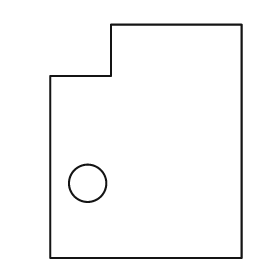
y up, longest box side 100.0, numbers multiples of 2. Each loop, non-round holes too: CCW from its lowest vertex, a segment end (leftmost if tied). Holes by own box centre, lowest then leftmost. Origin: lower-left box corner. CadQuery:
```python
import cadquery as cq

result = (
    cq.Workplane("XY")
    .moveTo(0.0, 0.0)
    .lineTo(82.0, 0.0)
    .lineTo(82.0, 100.0)
    .lineTo(26.0, 100.0)
    .lineTo(26.0, 78.0)
    .lineTo(0.0, 78.0)
    .close()
    .moveTo(16.0, 32.0)
    .circle(8.0)
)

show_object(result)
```